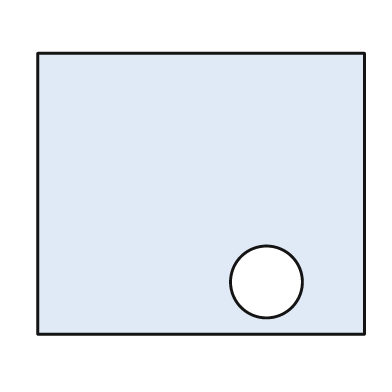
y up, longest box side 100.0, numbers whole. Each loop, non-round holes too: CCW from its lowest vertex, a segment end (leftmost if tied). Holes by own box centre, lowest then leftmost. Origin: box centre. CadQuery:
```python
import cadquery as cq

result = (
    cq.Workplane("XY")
    .moveTo(-50.0, -43.0)
    .lineTo(50.0, -43.0)
    .lineTo(50.0, 43.0)
    .lineTo(-50.0, 43.0)
    .close()
    .moveTo(20.0, -27.0)
    .circle(11.0)
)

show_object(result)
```